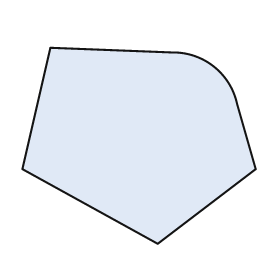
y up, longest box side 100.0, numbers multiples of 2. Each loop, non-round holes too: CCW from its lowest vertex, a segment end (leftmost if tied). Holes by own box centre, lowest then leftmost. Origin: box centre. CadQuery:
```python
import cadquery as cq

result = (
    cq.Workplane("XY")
    .moveTo(8.0, -42.0)
    .lineTo(50.0, -10.0)
    .lineTo(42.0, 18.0)
    .threePointArc((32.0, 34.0), (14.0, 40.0))
    .lineTo(-38.0, 42.0)
    .lineTo(-50.0, -10.0)
    .close()
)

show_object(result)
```